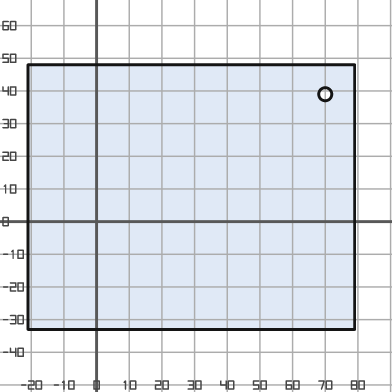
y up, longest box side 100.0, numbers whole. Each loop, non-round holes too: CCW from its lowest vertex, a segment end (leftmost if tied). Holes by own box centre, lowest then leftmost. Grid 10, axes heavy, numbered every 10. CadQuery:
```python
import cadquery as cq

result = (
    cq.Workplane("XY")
    .moveTo(-21.0, -33.0)
    .lineTo(79.0, -33.0)
    .lineTo(79.0, 48.0)
    .lineTo(-21.0, 48.0)
    .close()
    .moveTo(70.0, 39.0)
    .circle(2.0)
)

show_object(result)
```